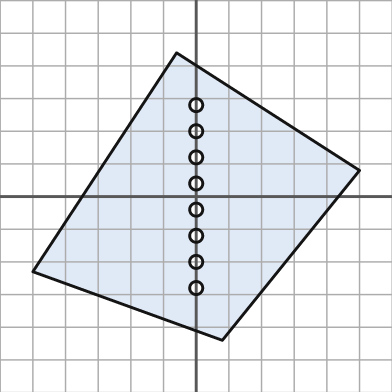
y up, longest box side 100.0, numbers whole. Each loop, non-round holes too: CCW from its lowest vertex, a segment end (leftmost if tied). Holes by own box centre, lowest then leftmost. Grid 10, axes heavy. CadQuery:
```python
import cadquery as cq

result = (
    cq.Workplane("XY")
    .moveTo(8.0, -44.0)
    .lineTo(50.0, 8.0)
    .lineTo(-6.0, 44.0)
    .lineTo(-50.0, -23.0)
    .close()
    .moveTo(0.0, -28.0)
    .circle(2.0)
    .moveTo(0.0, -20.0)
    .circle(2.0)
    .moveTo(0.0, -12.0)
    .circle(2.0)
    .moveTo(0.0, -4.0)
    .circle(2.0)
    .moveTo(0.0, 4.0)
    .circle(2.0)
    .moveTo(0.0, 12.0)
    .circle(2.0)
    .moveTo(0.0, 20.0)
    .circle(2.0)
    .moveTo(0.0, 28.0)
    .circle(2.0)
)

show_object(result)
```